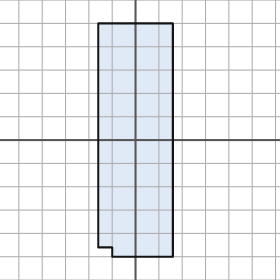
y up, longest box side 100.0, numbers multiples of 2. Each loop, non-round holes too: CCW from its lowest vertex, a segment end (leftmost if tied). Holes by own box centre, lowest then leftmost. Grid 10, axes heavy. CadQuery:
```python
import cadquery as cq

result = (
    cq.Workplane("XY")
    .moveTo(-10.0, -50.0)
    .lineTo(16.0, -50.0)
    .lineTo(16.0, 50.0)
    .lineTo(-16.0, 50.0)
    .lineTo(-16.0, -46.0)
    .lineTo(-10.0, -46.0)
    .close()
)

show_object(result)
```